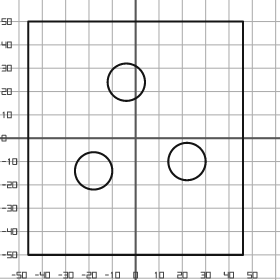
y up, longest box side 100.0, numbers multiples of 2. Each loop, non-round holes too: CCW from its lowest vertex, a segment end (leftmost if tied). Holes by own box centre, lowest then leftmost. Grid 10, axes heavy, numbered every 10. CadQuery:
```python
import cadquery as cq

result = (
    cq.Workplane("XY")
    .moveTo(-46.0, -50.0)
    .lineTo(46.0, -50.0)
    .lineTo(46.0, 50.0)
    .lineTo(-46.0, 50.0)
    .close()
    .moveTo(-18.0, -14.0)
    .circle(8.0)
    .moveTo(22.0, -10.0)
    .circle(8.0)
    .moveTo(-4.0, 24.0)
    .circle(8.0)
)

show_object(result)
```